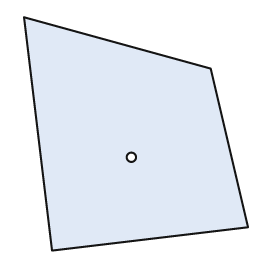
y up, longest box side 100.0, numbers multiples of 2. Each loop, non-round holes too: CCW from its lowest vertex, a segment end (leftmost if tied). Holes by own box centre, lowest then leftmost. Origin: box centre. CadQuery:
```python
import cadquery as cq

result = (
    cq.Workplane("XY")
    .moveTo(-36.0, -50.0)
    .lineTo(48.0, -40.0)
    .lineTo(32.0, 28.0)
    .lineTo(-48.0, 50.0)
    .close()
    .moveTo(-2.0, -10.0)
    .circle(2.0)
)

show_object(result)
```